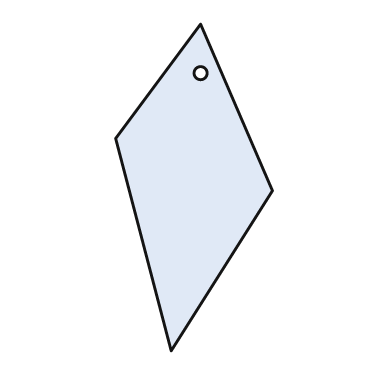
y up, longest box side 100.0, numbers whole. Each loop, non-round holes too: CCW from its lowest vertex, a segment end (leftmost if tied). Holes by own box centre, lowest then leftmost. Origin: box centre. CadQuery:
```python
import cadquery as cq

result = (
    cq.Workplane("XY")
    .moveTo(-7.0, -50.0)
    .lineTo(24.0, -1.0)
    .lineTo(2.0, 50.0)
    .lineTo(-24.0, 15.0)
    .close()
    .moveTo(2.0, 35.0)
    .circle(2.0)
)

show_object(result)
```